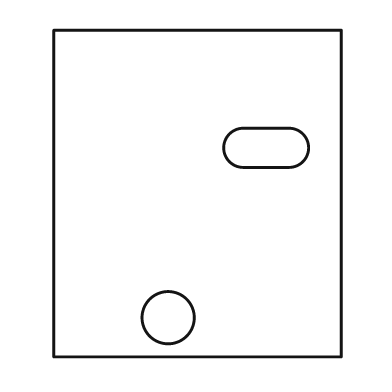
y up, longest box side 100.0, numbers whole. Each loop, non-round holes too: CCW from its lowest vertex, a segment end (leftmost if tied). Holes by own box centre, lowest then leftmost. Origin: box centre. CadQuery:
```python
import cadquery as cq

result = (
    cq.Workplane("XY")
    .moveTo(-44.0, -50.0)
    .lineTo(44.0, -50.0)
    .lineTo(44.0, 50.0)
    .lineTo(-44.0, 50.0)
    .close()
    .moveTo(-9.0, -38.0)
    .circle(8.0)
    .moveTo(14.0, 8.0)
    .lineTo(28.0, 8.0)
    .threePointArc((34.0, 14.0), (28.0, 20.0))
    .lineTo(14.0, 20.0)
    .threePointArc((8.0, 14.0), (14.0, 8.0))
    .close()
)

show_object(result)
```